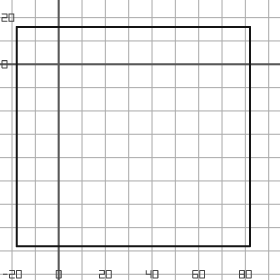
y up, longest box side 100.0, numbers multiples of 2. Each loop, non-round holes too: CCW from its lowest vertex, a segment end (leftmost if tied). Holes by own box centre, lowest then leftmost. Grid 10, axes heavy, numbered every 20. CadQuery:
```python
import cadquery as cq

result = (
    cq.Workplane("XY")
    .moveTo(-18.0, -78.0)
    .lineTo(82.0, -78.0)
    .lineTo(82.0, 16.0)
    .lineTo(-18.0, 16.0)
    .close()
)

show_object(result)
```